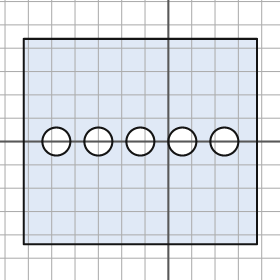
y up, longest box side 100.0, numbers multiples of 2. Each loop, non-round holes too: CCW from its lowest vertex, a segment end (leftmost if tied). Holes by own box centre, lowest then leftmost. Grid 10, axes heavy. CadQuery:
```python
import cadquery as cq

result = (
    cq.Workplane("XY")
    .moveTo(-62.0, -44.0)
    .lineTo(38.0, -44.0)
    .lineTo(38.0, 44.0)
    .lineTo(-62.0, 44.0)
    .close()
    .moveTo(-48.0, 0.0)
    .circle(6.0)
    .moveTo(-30.0, 0.0)
    .circle(6.0)
    .moveTo(-12.0, 0.0)
    .circle(6.0)
    .moveTo(6.0, 0.0)
    .circle(6.0)
    .moveTo(24.0, 0.0)
    .circle(6.0)
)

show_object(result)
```